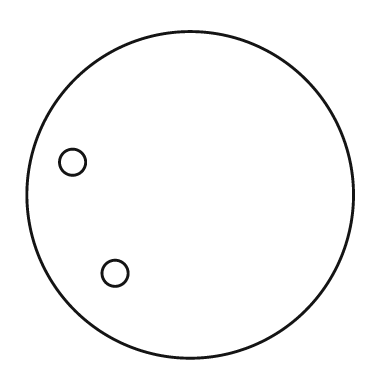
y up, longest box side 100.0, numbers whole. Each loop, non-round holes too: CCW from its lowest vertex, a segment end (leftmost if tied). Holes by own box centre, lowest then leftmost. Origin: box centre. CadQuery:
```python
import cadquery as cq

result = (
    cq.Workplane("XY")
    .moveTo(0.0, 0.0)
    .circle(50.0)
    .moveTo(-23.0, -24.0)
    .circle(4.0)
    .moveTo(-36.0, 10.0)
    .circle(4.0)
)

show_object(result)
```